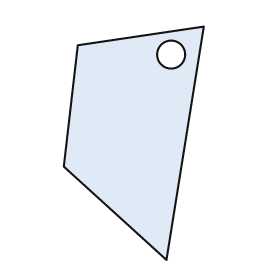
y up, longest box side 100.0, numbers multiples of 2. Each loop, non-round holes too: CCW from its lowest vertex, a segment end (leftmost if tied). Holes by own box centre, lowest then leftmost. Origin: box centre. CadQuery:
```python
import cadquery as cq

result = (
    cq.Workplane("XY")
    .moveTo(14.0, -50.0)
    .lineTo(30.0, 50.0)
    .lineTo(-24.0, 42.0)
    .lineTo(-30.0, -10.0)
    .close()
    .moveTo(16.0, 38.0)
    .circle(6.0)
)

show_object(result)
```